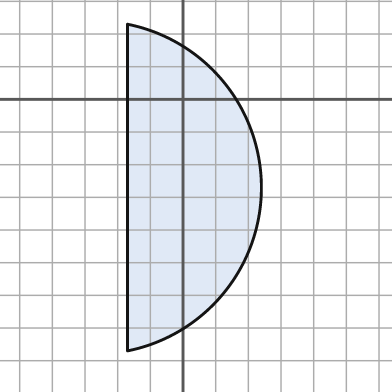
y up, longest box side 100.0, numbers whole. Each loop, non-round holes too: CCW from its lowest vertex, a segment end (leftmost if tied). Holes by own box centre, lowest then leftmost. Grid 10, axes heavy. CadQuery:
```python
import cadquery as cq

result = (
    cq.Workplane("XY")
    .moveTo(-17.0, -77.0)
    .threePointArc((24.0, -27.0), (-17.0, 23.0))
    .close()
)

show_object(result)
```